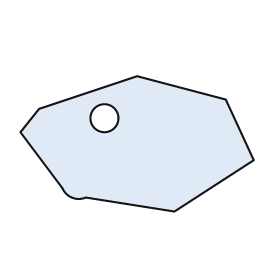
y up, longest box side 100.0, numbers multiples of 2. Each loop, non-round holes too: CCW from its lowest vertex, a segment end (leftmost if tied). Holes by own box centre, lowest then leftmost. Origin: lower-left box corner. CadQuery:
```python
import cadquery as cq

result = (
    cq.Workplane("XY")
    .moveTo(66.0, 0.0)
    .lineTo(100.0, 22.0)
    .lineTo(88.0, 48.0)
    .lineTo(50.0, 58.0)
    .lineTo(8.0, 44.0)
    .lineTo(0.0, 34.0)
    .lineTo(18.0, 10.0)
    .threePointArc((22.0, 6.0), (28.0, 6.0))
    .close()
    .moveTo(36.0, 40.0)
    .circle(6.0)
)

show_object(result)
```